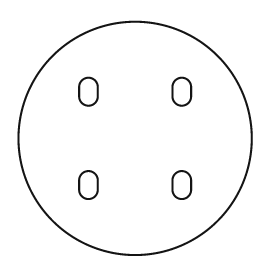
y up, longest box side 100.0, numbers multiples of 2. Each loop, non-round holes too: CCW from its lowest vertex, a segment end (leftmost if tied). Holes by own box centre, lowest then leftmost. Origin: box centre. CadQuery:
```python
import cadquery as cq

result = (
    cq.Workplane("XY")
    .moveTo(0.0, 0.0)
    .circle(50.0)
    .moveTo(-24.0, -22.0)
    .threePointArc((-20.0, -26.0), (-16.0, -22.0))
    .lineTo(-16.0, -18.0)
    .threePointArc((-20.0, -14.0), (-24.0, -18.0))
    .close()
    .moveTo(16.0, -22.0)
    .threePointArc((20.0, -26.0), (24.0, -22.0))
    .lineTo(24.0, -18.0)
    .threePointArc((20.0, -14.0), (16.0, -18.0))
    .close()
    .moveTo(-24.0, 18.0)
    .threePointArc((-20.0, 14.0), (-16.0, 18.0))
    .lineTo(-16.0, 22.0)
    .threePointArc((-20.0, 26.0), (-24.0, 22.0))
    .close()
    .moveTo(16.0, 18.0)
    .threePointArc((20.0, 14.0), (24.0, 18.0))
    .lineTo(24.0, 22.0)
    .threePointArc((20.0, 26.0), (16.0, 22.0))
    .close()
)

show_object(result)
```